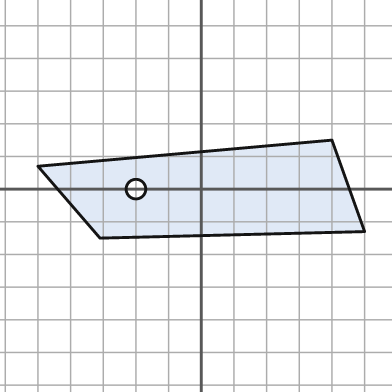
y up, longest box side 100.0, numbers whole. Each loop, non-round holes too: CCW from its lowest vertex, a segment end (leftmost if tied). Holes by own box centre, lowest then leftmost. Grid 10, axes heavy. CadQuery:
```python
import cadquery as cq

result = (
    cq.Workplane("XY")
    .moveTo(-31.0, -15.0)
    .lineTo(50.0, -13.0)
    .lineTo(40.0, 15.0)
    .lineTo(-50.0, 7.0)
    .close()
    .moveTo(-20.0, 0.0)
    .circle(3.0)
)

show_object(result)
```